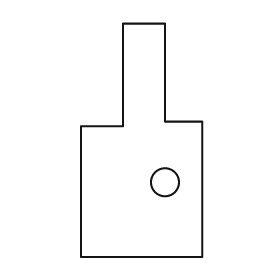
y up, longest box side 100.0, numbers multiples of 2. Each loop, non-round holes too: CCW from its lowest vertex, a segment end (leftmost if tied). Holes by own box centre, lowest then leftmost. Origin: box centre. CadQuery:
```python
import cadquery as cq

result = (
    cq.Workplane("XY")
    .moveTo(-26.0, -50.0)
    .lineTo(26.0, -50.0)
    .lineTo(26.0, 8.0)
    .lineTo(10.0, 8.0)
    .lineTo(10.0, 50.0)
    .lineTo(-8.0, 50.0)
    .lineTo(-8.0, 6.0)
    .lineTo(-26.0, 6.0)
    .close()
    .moveTo(10.0, -18.0)
    .circle(6.0)
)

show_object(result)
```